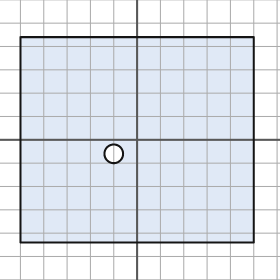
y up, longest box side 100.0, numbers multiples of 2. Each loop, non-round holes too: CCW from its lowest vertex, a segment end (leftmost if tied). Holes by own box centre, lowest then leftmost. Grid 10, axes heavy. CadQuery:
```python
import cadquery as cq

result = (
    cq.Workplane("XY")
    .moveTo(-50.0, -44.0)
    .lineTo(50.0, -44.0)
    .lineTo(50.0, 44.0)
    .lineTo(-50.0, 44.0)
    .close()
    .moveTo(-10.0, -6.0)
    .circle(4.0)
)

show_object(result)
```